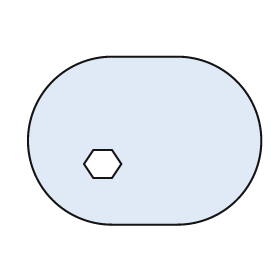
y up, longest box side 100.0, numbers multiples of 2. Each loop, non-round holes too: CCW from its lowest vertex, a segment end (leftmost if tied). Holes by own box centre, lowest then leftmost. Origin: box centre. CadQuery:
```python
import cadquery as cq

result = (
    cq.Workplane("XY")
    .moveTo(-14.0, -36.0)
    .lineTo(14.0, -36.0)
    .threePointArc((50.0, 0.0), (14.0, 36.0))
    .lineTo(-14.0, 36.0)
    .threePointArc((-50.0, 0.0), (-14.0, -36.0))
    .close()
    .moveTo(-22.0, -16.0)
    .lineTo(-14.0, -16.0)
    .lineTo(-10.0, -10.0)
    .lineTo(-14.0, -4.0)
    .lineTo(-22.0, -4.0)
    .lineTo(-26.0, -10.0)
    .close()
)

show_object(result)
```